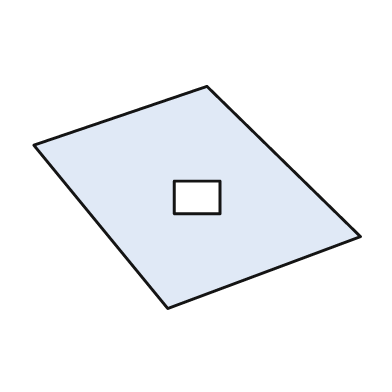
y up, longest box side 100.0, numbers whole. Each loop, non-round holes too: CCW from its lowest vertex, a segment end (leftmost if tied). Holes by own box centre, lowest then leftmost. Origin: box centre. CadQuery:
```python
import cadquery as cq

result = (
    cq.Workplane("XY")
    .moveTo(-9.0, -34.0)
    .lineTo(50.0, -12.0)
    .lineTo(3.0, 34.0)
    .lineTo(-50.0, 16.0)
    .close()
    .moveTo(-7.0, -5.0)
    .lineTo(7.0, -5.0)
    .lineTo(7.0, 5.0)
    .lineTo(-7.0, 5.0)
    .close()
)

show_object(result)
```